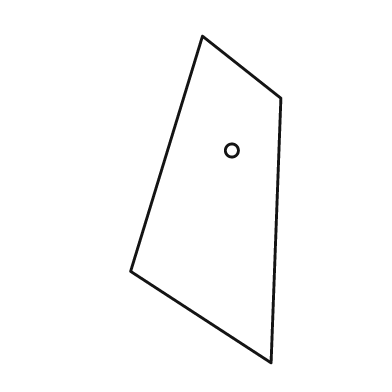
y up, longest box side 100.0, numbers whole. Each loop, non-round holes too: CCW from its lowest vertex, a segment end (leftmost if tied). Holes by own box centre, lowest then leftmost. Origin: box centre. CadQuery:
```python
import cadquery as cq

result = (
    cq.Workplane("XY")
    .moveTo(20.0, -50.0)
    .lineTo(23.0, 31.0)
    .lineTo(-1.0, 50.0)
    .lineTo(-23.0, -22.0)
    .close()
    .moveTo(8.0, 15.0)
    .circle(2.0)
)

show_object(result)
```